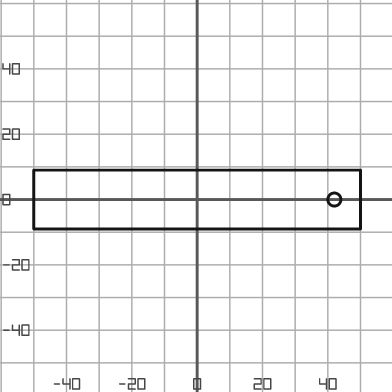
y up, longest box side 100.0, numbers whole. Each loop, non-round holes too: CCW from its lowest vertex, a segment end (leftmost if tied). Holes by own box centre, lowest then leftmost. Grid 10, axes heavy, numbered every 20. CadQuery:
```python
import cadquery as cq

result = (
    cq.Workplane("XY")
    .moveTo(-50.0, -9.0)
    .lineTo(50.0, -9.0)
    .lineTo(50.0, 9.0)
    .lineTo(-50.0, 9.0)
    .close()
    .moveTo(42.0, 0.0)
    .circle(2.0)
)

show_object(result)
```